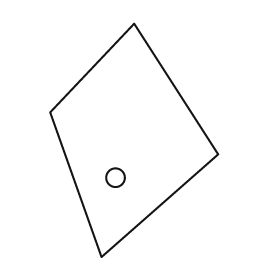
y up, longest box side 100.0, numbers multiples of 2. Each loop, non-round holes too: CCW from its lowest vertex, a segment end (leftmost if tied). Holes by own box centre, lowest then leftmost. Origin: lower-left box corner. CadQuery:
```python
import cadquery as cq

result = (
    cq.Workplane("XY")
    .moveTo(22.0, 0.0)
    .lineTo(72.0, 44.0)
    .lineTo(36.0, 100.0)
    .lineTo(0.0, 62.0)
    .close()
    .moveTo(28.0, 34.0)
    .circle(4.0)
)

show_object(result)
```